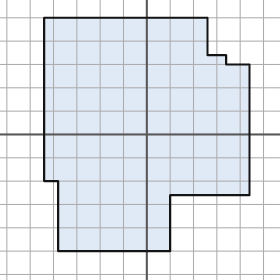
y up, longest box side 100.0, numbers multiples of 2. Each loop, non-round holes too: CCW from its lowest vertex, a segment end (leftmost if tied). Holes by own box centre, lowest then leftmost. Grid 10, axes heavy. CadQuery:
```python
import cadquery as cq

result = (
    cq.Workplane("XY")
    .moveTo(-38.0, -50.0)
    .lineTo(10.0, -50.0)
    .lineTo(10.0, -26.0)
    .lineTo(44.0, -26.0)
    .lineTo(44.0, 30.0)
    .lineTo(34.0, 30.0)
    .lineTo(34.0, 34.0)
    .lineTo(26.0, 34.0)
    .lineTo(26.0, 50.0)
    .lineTo(-44.0, 50.0)
    .lineTo(-44.0, -20.0)
    .lineTo(-38.0, -20.0)
    .close()
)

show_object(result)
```